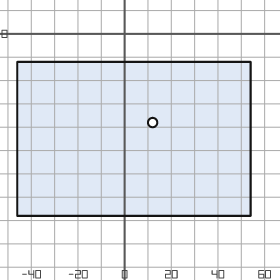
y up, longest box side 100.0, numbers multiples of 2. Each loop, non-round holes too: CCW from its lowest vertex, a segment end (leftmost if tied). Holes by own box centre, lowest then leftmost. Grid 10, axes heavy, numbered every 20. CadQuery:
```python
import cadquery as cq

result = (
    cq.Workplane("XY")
    .moveTo(-46.0, -78.0)
    .lineTo(54.0, -78.0)
    .lineTo(54.0, -12.0)
    .lineTo(-46.0, -12.0)
    .close()
    .moveTo(12.0, -38.0)
    .circle(2.0)
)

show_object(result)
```